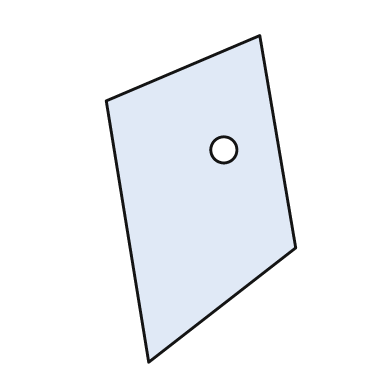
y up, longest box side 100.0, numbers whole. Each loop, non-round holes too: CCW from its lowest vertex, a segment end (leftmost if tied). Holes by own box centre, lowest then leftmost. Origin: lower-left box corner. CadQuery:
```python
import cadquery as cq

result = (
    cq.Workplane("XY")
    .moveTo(13.0, 0.0)
    .lineTo(58.0, 35.0)
    .lineTo(47.0, 100.0)
    .lineTo(0.0, 80.0)
    .close()
    .moveTo(36.0, 65.0)
    .circle(4.0)
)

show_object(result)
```